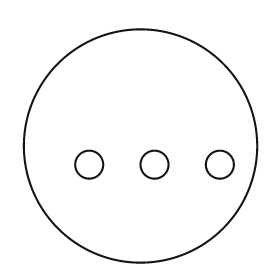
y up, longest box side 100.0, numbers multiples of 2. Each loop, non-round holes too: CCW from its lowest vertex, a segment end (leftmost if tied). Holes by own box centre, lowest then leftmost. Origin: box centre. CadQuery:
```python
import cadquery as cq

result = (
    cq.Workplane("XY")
    .moveTo(0.0, 0.0)
    .circle(50.0)
    .moveTo(-22.0, -8.0)
    .circle(6.0)
    .moveTo(6.0, -8.0)
    .circle(6.0)
    .moveTo(34.0, -8.0)
    .circle(6.0)
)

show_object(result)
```